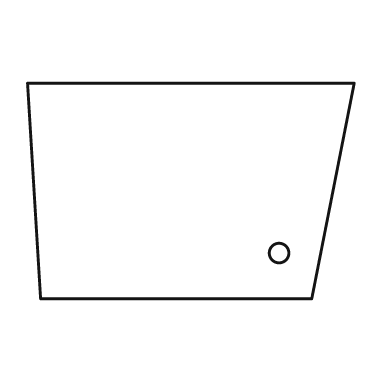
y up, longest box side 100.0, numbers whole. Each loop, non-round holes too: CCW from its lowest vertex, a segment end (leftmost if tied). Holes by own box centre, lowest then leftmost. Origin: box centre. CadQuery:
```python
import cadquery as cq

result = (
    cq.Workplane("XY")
    .moveTo(-46.0, -33.0)
    .lineTo(37.0, -33.0)
    .lineTo(50.0, 33.0)
    .lineTo(-50.0, 33.0)
    .close()
    .moveTo(27.0, -19.0)
    .circle(3.0)
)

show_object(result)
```